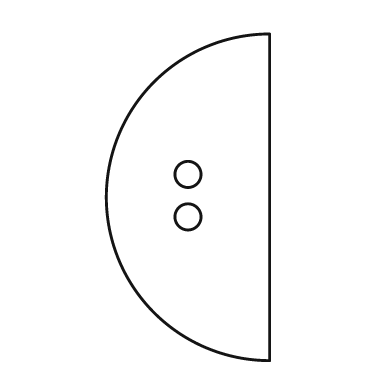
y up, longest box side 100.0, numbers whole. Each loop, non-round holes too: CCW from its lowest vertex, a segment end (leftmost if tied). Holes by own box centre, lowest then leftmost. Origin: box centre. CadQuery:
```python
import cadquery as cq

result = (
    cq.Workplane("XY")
    .moveTo(25.0, -50.0)
    .lineTo(25.0, 50.0)
    .threePointArc((-25.0, 0.0), (25.0, -50.0))
    .close()
    .moveTo(0.0, -6.0)
    .circle(4.0)
    .moveTo(0.0, 7.0)
    .circle(4.0)
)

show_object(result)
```